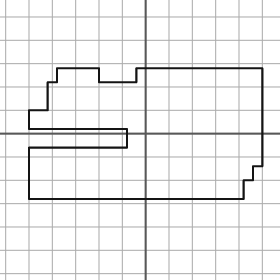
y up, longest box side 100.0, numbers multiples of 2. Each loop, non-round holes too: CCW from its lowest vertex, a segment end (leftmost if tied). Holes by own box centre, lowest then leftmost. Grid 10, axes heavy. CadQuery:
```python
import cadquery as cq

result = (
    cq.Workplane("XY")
    .moveTo(-50.0, -28.0)
    .lineTo(42.0, -28.0)
    .lineTo(42.0, -20.0)
    .lineTo(46.0, -20.0)
    .lineTo(46.0, -14.0)
    .lineTo(50.0, -14.0)
    .lineTo(50.0, 28.0)
    .lineTo(-4.0, 28.0)
    .lineTo(-4.0, 22.0)
    .lineTo(-20.0, 22.0)
    .lineTo(-20.0, 28.0)
    .lineTo(-38.0, 28.0)
    .lineTo(-38.0, 22.0)
    .lineTo(-42.0, 22.0)
    .lineTo(-42.0, 10.0)
    .lineTo(-50.0, 10.0)
    .lineTo(-50.0, 2.0)
    .lineTo(-8.0, 2.0)
    .lineTo(-8.0, -6.0)
    .lineTo(-50.0, -6.0)
    .close()
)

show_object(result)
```